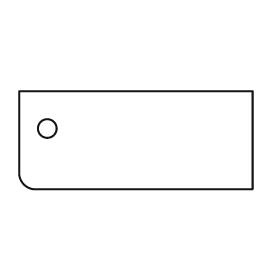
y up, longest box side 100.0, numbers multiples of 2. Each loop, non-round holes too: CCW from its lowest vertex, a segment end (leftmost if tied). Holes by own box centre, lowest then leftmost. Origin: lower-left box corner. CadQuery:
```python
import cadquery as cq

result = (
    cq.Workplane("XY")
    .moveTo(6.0, 0.0)
    .lineTo(100.0, 0.0)
    .lineTo(100.0, 42.0)
    .lineTo(0.0, 42.0)
    .lineTo(0.0, 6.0)
    .threePointArc((2.0, 2.0), (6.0, 0.0))
    .close()
    .moveTo(12.0, 26.0)
    .circle(4.0)
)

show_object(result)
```